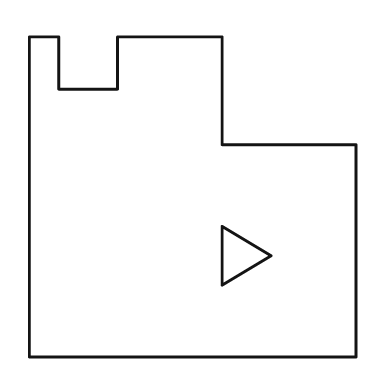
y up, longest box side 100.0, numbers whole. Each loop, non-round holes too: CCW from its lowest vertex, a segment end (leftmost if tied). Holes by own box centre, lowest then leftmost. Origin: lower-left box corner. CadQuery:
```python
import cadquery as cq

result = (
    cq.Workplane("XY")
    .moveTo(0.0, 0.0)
    .lineTo(100.0, 0.0)
    .lineTo(100.0, 65.0)
    .lineTo(59.0, 65.0)
    .lineTo(59.0, 98.0)
    .lineTo(27.0, 98.0)
    .lineTo(27.0, 82.0)
    .lineTo(9.0, 82.0)
    .lineTo(9.0, 98.0)
    .lineTo(0.0, 98.0)
    .close()
    .moveTo(59.0, 22.0)
    .lineTo(74.0, 31.0)
    .lineTo(59.0, 40.0)
    .close()
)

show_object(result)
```